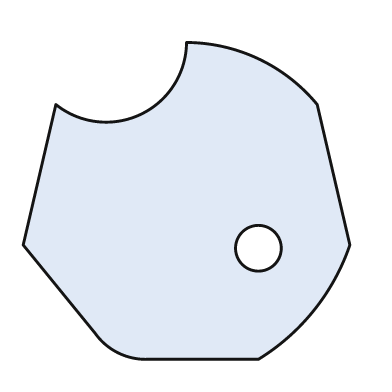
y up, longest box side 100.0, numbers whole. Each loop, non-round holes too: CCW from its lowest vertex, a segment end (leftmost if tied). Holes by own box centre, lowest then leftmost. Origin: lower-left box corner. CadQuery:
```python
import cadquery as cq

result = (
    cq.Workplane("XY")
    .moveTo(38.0, 0.0)
    .lineTo(72.0, 0.0)
    .threePointArc((89.0, 15.0), (100.0, 35.0))
    .lineTo(90.0, 78.0)
    .threePointArc((72.0, 92.0), (50.0, 97.0))
    .threePointArc((36.0, 75.0), (10.0, 78.0))
    .lineTo(0.0, 35.0)
    .lineTo(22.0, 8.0)
    .threePointArc((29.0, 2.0), (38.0, 0.0))
    .close()
    .moveTo(72.0, 34.0)
    .circle(7.0)
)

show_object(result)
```